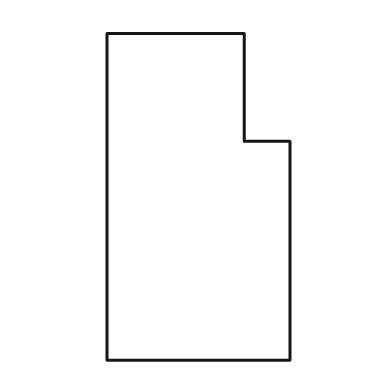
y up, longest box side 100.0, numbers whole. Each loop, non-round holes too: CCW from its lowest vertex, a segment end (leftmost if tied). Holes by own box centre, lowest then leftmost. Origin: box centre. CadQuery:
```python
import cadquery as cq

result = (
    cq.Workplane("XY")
    .moveTo(-28.0, -50.0)
    .lineTo(28.0, -50.0)
    .lineTo(28.0, 17.0)
    .lineTo(14.0, 17.0)
    .lineTo(14.0, 50.0)
    .lineTo(-28.0, 50.0)
    .close()
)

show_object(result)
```